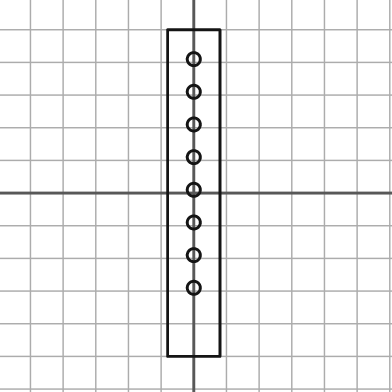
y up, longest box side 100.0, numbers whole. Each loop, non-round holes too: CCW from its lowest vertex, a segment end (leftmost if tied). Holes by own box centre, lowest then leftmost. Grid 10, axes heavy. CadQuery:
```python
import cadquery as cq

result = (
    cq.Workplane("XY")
    .moveTo(-8.0, -50.0)
    .lineTo(8.0, -50.0)
    .lineTo(8.0, 50.0)
    .lineTo(-8.0, 50.0)
    .close()
    .moveTo(0.0, -29.0)
    .circle(2.0)
    .moveTo(0.0, -19.0)
    .circle(2.0)
    .moveTo(0.0, -9.0)
    .circle(2.0)
    .moveTo(0.0, 1.0)
    .circle(2.0)
    .moveTo(0.0, 11.0)
    .circle(2.0)
    .moveTo(0.0, 21.0)
    .circle(2.0)
    .moveTo(0.0, 31.0)
    .circle(2.0)
    .moveTo(0.0, 41.0)
    .circle(2.0)
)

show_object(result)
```